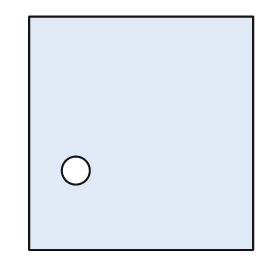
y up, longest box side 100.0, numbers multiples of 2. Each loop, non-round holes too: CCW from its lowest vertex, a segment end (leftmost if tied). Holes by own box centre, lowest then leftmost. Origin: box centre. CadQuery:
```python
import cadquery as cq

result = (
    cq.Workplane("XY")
    .moveTo(-48.0, -50.0)
    .lineTo(48.0, -50.0)
    .lineTo(48.0, 50.0)
    .lineTo(-48.0, 50.0)
    .close()
    .moveTo(-28.0, -16.0)
    .circle(6.0)
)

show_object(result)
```